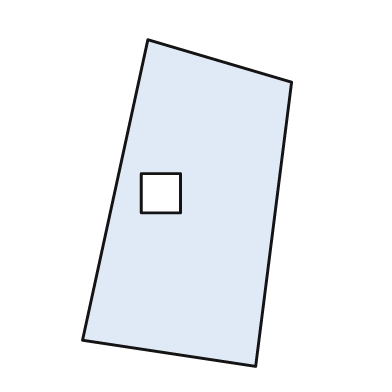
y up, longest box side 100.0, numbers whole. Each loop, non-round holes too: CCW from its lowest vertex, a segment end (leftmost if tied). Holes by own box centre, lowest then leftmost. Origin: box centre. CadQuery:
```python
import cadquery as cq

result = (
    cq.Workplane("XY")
    .moveTo(21.0, -50.0)
    .lineTo(32.0, 37.0)
    .lineTo(-12.0, 50.0)
    .lineTo(-32.0, -42.0)
    .close()
    .moveTo(-14.0, -3.0)
    .lineTo(-2.0, -3.0)
    .lineTo(-2.0, 9.0)
    .lineTo(-14.0, 9.0)
    .close()
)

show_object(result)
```